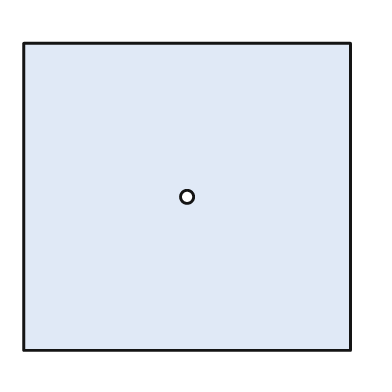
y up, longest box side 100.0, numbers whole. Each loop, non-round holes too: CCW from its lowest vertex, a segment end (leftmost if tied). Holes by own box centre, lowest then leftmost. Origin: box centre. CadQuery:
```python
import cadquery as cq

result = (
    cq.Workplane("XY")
    .moveTo(-50.0, -47.0)
    .lineTo(50.0, -47.0)
    .lineTo(50.0, 47.0)
    .lineTo(-50.0, 47.0)
    .close()
    .moveTo(0.0, 0.0)
    .circle(2.0)
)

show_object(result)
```